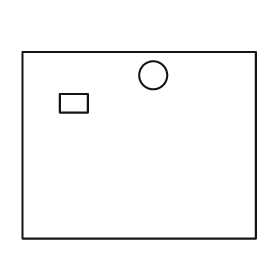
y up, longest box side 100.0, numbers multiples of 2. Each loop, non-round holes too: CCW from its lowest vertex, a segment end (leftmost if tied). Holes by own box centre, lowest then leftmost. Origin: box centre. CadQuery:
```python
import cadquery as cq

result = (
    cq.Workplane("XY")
    .moveTo(-50.0, -40.0)
    .lineTo(50.0, -40.0)
    .lineTo(50.0, 40.0)
    .lineTo(-50.0, 40.0)
    .close()
    .moveTo(-34.0, 14.0)
    .lineTo(-22.0, 14.0)
    .lineTo(-22.0, 22.0)
    .lineTo(-34.0, 22.0)
    .close()
    .moveTo(6.0, 30.0)
    .circle(6.0)
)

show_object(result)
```